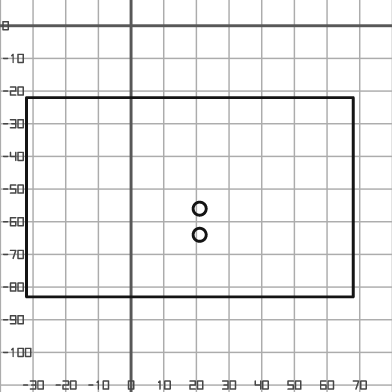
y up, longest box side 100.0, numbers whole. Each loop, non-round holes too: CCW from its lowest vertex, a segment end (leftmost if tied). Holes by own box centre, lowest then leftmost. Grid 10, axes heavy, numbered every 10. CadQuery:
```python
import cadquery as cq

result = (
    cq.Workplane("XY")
    .moveTo(-32.0, -83.0)
    .lineTo(68.0, -83.0)
    .lineTo(68.0, -22.0)
    .lineTo(-32.0, -22.0)
    .close()
    .moveTo(21.0, -64.0)
    .circle(2.0)
    .moveTo(21.0, -56.0)
    .circle(2.0)
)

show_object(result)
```